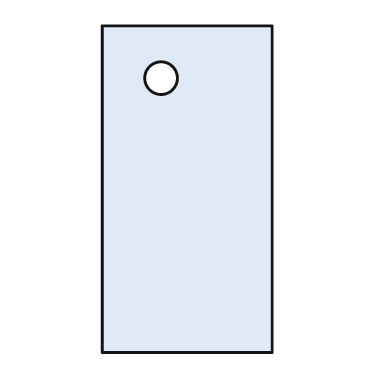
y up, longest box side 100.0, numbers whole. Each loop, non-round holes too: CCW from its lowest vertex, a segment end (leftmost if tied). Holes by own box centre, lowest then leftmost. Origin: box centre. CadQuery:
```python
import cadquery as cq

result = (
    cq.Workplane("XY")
    .moveTo(-26.0, -50.0)
    .lineTo(26.0, -50.0)
    .lineTo(26.0, 50.0)
    .lineTo(-26.0, 50.0)
    .close()
    .moveTo(-8.0, 34.0)
    .circle(5.0)
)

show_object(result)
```